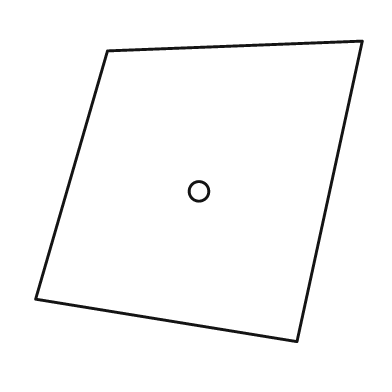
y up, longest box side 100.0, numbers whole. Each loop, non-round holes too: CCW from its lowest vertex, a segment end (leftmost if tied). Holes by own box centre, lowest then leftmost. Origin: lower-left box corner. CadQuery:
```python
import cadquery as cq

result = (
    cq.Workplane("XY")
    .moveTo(80.0, 0.0)
    .lineTo(100.0, 92.0)
    .lineTo(22.0, 89.0)
    .lineTo(0.0, 13.0)
    .close()
    .moveTo(50.0, 46.0)
    .circle(3.0)
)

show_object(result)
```